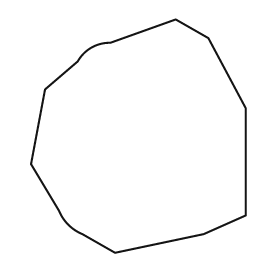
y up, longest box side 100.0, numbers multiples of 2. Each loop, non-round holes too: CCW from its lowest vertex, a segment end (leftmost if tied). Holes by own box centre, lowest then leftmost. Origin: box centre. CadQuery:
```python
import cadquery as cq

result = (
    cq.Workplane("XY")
    .moveTo(-10.0, -50.0)
    .lineTo(28.0, -42.0)
    .lineTo(46.0, -34.0)
    .lineTo(46.0, 12.0)
    .lineTo(30.0, 42.0)
    .lineTo(16.0, 50.0)
    .lineTo(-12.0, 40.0)
    .threePointArc((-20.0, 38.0), (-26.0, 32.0))
    .lineTo(-40.0, 20.0)
    .lineTo(-46.0, -12.0)
    .lineTo(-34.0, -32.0)
    .threePointArc((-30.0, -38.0), (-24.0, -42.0))
    .close()
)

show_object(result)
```